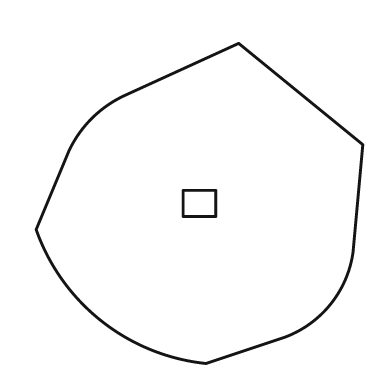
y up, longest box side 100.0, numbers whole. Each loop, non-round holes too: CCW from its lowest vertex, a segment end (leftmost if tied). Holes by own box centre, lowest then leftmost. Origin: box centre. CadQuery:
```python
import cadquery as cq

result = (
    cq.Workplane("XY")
    .moveTo(2.0, -49.0)
    .lineTo(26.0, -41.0)
    .threePointArc((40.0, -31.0), (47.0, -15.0))
    .lineTo(50.0, 18.0)
    .lineTo(12.0, 49.0)
    .lineTo(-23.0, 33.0)
    .threePointArc((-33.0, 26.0), (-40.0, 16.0))
    .lineTo(-50.0, -8.0)
    .threePointArc((-30.0, -36.0), (2.0, -49.0))
    .close()
    .moveTo(-5.0, -4.0)
    .lineTo(5.0, -4.0)
    .lineTo(5.0, 4.0)
    .lineTo(-5.0, 4.0)
    .close()
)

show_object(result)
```